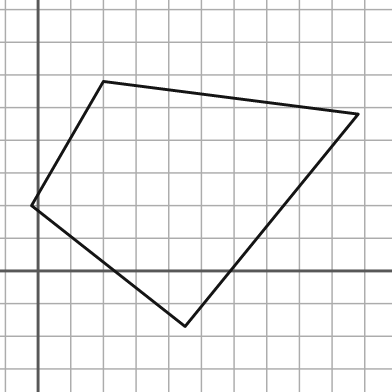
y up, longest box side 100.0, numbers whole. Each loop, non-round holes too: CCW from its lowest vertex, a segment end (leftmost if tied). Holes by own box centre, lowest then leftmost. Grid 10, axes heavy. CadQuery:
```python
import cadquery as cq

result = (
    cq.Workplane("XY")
    .moveTo(45.0, -17.0)
    .lineTo(98.0, 48.0)
    .lineTo(20.0, 58.0)
    .lineTo(-2.0, 20.0)
    .close()
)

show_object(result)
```